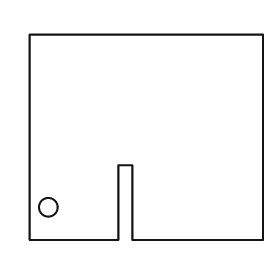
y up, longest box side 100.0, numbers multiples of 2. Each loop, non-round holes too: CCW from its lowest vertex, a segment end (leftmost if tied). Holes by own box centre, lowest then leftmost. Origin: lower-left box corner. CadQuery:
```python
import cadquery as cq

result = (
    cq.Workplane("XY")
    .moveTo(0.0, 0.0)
    .lineTo(38.0, 0.0)
    .lineTo(38.0, 32.0)
    .lineTo(44.0, 32.0)
    .lineTo(44.0, 0.0)
    .lineTo(100.0, 0.0)
    .lineTo(100.0, 88.0)
    .lineTo(0.0, 88.0)
    .close()
    .moveTo(8.0, 14.0)
    .circle(4.0)
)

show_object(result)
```